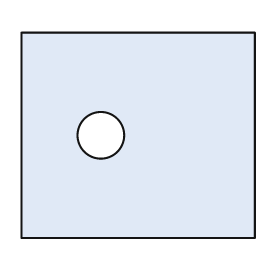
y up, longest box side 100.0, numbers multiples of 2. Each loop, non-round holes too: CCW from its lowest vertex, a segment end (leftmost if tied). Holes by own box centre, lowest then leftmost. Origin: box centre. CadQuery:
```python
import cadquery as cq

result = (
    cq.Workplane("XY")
    .moveTo(-50.0, -44.0)
    .lineTo(50.0, -44.0)
    .lineTo(50.0, 44.0)
    .lineTo(-50.0, 44.0)
    .close()
    .moveTo(-16.0, 0.0)
    .circle(10.0)
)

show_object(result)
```